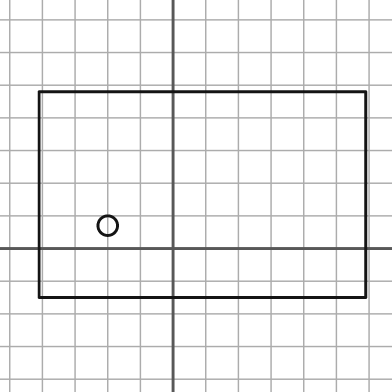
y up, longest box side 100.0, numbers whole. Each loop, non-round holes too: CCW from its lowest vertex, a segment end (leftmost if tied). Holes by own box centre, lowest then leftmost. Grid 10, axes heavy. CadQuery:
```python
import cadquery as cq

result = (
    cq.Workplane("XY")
    .moveTo(-41.0, -15.0)
    .lineTo(59.0, -15.0)
    .lineTo(59.0, 48.0)
    .lineTo(-41.0, 48.0)
    .close()
    .moveTo(-20.0, 7.0)
    .circle(3.0)
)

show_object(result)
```